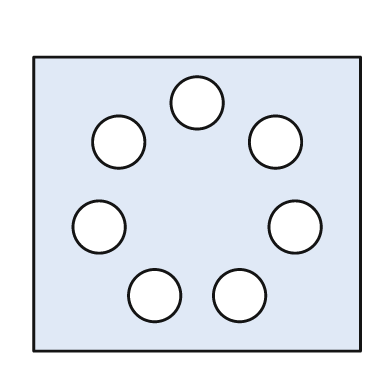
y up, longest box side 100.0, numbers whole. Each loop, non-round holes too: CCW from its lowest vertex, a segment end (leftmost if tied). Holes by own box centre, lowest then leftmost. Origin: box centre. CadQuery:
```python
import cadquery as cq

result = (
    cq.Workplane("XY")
    .moveTo(-50.0, -45.0)
    .lineTo(50.0, -45.0)
    .lineTo(50.0, 45.0)
    .lineTo(-50.0, 45.0)
    .close()
    .moveTo(-13.0, -28.0)
    .circle(8.0)
    .moveTo(13.0, -28.0)
    .circle(8.0)
    .moveTo(-30.0, -7.0)
    .circle(8.0)
    .moveTo(30.0, -7.0)
    .circle(8.0)
    .moveTo(-24.0, 19.0)
    .circle(8.0)
    .moveTo(24.0, 19.0)
    .circle(8.0)
    .moveTo(0.0, 31.0)
    .circle(8.0)
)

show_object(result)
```